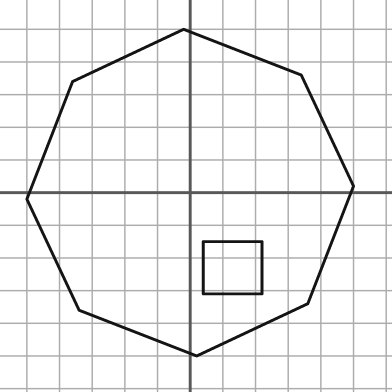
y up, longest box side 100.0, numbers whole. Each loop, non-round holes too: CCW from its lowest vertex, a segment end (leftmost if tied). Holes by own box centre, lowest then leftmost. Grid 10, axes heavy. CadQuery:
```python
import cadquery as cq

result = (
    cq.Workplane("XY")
    .moveTo(2.0, -50.0)
    .lineTo(36.0, -34.0)
    .lineTo(50.0, 2.0)
    .lineTo(34.0, 36.0)
    .lineTo(-2.0, 50.0)
    .lineTo(-36.0, 34.0)
    .lineTo(-50.0, -2.0)
    .lineTo(-34.0, -36.0)
    .close()
    .moveTo(4.0, -31.0)
    .lineTo(22.0, -31.0)
    .lineTo(22.0, -15.0)
    .lineTo(4.0, -15.0)
    .close()
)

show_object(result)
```